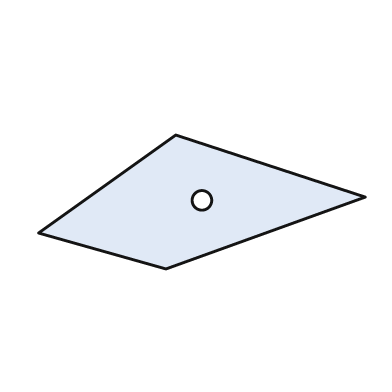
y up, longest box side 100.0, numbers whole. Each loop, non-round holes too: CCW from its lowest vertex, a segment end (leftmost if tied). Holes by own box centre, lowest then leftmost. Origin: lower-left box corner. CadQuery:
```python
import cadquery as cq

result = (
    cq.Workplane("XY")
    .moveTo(39.0, 0.0)
    .lineTo(100.0, 22.0)
    .lineTo(42.0, 41.0)
    .lineTo(0.0, 11.0)
    .close()
    .moveTo(50.0, 21.0)
    .circle(3.0)
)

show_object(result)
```